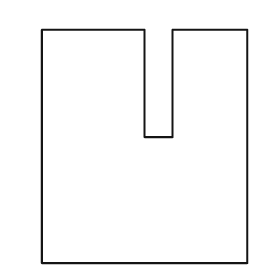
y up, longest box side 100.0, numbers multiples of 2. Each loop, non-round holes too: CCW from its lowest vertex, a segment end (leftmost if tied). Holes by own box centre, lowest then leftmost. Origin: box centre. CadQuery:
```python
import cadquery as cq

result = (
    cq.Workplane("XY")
    .moveTo(-44.0, -50.0)
    .lineTo(44.0, -50.0)
    .lineTo(44.0, 50.0)
    .lineTo(12.0, 50.0)
    .lineTo(12.0, 4.0)
    .lineTo(0.0, 4.0)
    .lineTo(0.0, 50.0)
    .lineTo(-44.0, 50.0)
    .close()
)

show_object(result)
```